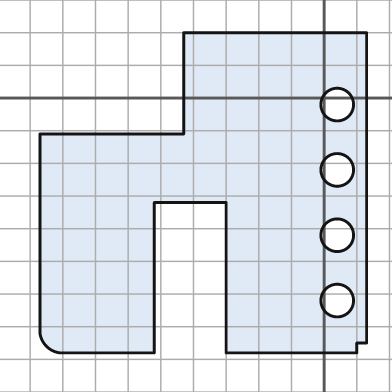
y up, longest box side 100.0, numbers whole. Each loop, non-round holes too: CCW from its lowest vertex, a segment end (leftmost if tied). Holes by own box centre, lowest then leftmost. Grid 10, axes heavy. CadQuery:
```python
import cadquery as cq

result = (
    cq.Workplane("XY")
    .moveTo(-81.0, -78.0)
    .lineTo(-52.0, -78.0)
    .lineTo(-52.0, -32.0)
    .lineTo(-30.0, -32.0)
    .lineTo(-30.0, -78.0)
    .lineTo(10.0, -78.0)
    .lineTo(10.0, -75.0)
    .lineTo(13.0, -75.0)
    .lineTo(13.0, 20.0)
    .lineTo(-43.0, 20.0)
    .lineTo(-43.0, -11.0)
    .lineTo(-87.0, -11.0)
    .lineTo(-87.0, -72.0)
    .threePointArc((-85.0, -76.0), (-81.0, -78.0))
    .close()
    .moveTo(4.0, -62.0)
    .circle(5.0)
    .moveTo(4.0, -42.0)
    .circle(5.0)
    .moveTo(4.0, -22.0)
    .circle(5.0)
    .moveTo(4.0, -2.0)
    .circle(5.0)
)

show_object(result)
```